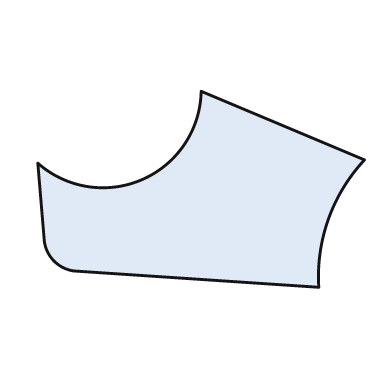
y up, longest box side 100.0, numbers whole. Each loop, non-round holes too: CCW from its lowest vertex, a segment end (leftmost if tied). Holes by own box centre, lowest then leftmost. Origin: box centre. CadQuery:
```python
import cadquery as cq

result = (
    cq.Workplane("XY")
    .moveTo(36.0, -30.0)
    .threePointArc((39.0, -9.0), (50.0, 9.0))
    .lineTo(0.0, 30.0)
    .threePointArc((-18.0, 3.0), (-50.0, 8.0))
    .lineTo(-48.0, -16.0)
    .threePointArc((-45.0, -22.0), (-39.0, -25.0))
    .close()
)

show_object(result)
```